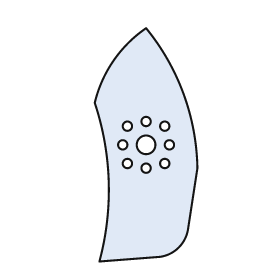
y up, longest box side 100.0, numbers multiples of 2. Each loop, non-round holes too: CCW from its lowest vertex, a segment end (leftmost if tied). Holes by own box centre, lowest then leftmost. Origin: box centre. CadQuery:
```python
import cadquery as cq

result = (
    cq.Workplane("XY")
    .moveTo(-20.0, -50.0)
    .lineTo(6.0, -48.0)
    .threePointArc((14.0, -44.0), (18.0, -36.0))
    .lineTo(22.0, -10.0)
    .threePointArc((16.0, 22.0), (0.0, 50.0))
    .threePointArc((-14.0, 36.0), (-22.0, 18.0))
    .threePointArc((-16.0, -16.0), (-20.0, -50.0))
    .close()
    .moveTo(0.0, -10.0)
    .circle(2.0)
    .moveTo(-8.0, -8.0)
    .circle(2.0)
    .moveTo(8.0, -8.0)
    .circle(2.0)
    .moveTo(-10.0, 0.0)
    .circle(2.0)
    .moveTo(0.0, 0.0)
    .circle(4.0)
    .moveTo(10.0, 0.0)
    .circle(2.0)
    .moveTo(-8.0, 8.0)
    .circle(2.0)
    .moveTo(8.0, 8.0)
    .circle(2.0)
    .moveTo(0.0, 10.0)
    .circle(2.0)
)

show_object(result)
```